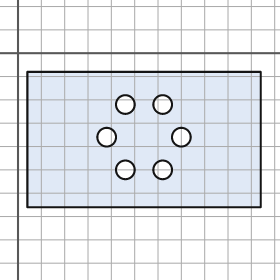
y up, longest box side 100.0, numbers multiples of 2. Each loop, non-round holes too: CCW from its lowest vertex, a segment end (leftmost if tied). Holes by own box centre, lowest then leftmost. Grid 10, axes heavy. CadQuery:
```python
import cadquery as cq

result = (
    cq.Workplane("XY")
    .moveTo(4.0, -66.0)
    .lineTo(104.0, -66.0)
    .lineTo(104.0, -8.0)
    .lineTo(4.0, -8.0)
    .close()
    .moveTo(46.0, -50.0)
    .circle(4.0)
    .moveTo(62.0, -50.0)
    .circle(4.0)
    .moveTo(38.0, -36.0)
    .circle(4.0)
    .moveTo(70.0, -36.0)
    .circle(4.0)
    .moveTo(46.0, -22.0)
    .circle(4.0)
    .moveTo(62.0, -22.0)
    .circle(4.0)
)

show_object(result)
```